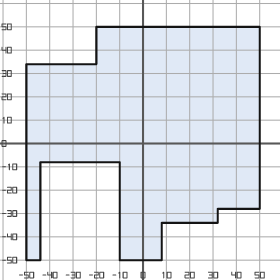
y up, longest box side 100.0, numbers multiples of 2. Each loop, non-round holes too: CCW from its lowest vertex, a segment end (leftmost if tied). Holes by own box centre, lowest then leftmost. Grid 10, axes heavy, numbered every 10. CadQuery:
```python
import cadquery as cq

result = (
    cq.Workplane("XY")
    .moveTo(-50.0, -50.0)
    .lineTo(-44.0, -50.0)
    .lineTo(-44.0, -8.0)
    .lineTo(-10.0, -8.0)
    .lineTo(-10.0, -50.0)
    .lineTo(8.0, -50.0)
    .lineTo(8.0, -34.0)
    .lineTo(32.0, -34.0)
    .lineTo(32.0, -28.0)
    .lineTo(50.0, -28.0)
    .lineTo(50.0, 50.0)
    .lineTo(-20.0, 50.0)
    .lineTo(-20.0, 34.0)
    .lineTo(-50.0, 34.0)
    .close()
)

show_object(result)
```